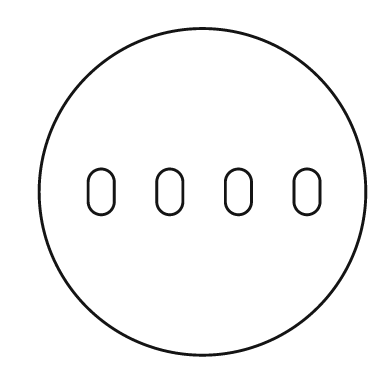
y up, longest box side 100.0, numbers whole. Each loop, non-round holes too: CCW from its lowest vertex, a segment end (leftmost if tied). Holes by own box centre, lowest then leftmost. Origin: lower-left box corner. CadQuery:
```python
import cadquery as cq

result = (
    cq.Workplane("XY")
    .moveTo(50.0, 50.0)
    .circle(50.0)
    .moveTo(15.0, 47.0)
    .threePointArc((19.0, 43.0), (23.0, 47.0))
    .lineTo(23.0, 53.0)
    .threePointArc((19.0, 57.0), (15.0, 53.0))
    .close()
    .moveTo(36.0, 47.0)
    .threePointArc((40.0, 43.0), (44.0, 47.0))
    .lineTo(44.0, 53.0)
    .threePointArc((40.0, 57.0), (36.0, 53.0))
    .close()
    .moveTo(57.0, 47.0)
    .threePointArc((61.0, 43.0), (65.0, 47.0))
    .lineTo(65.0, 53.0)
    .threePointArc((61.0, 57.0), (57.0, 53.0))
    .close()
    .moveTo(78.0, 47.0)
    .threePointArc((82.0, 43.0), (86.0, 47.0))
    .lineTo(86.0, 53.0)
    .threePointArc((82.0, 57.0), (78.0, 53.0))
    .close()
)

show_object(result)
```